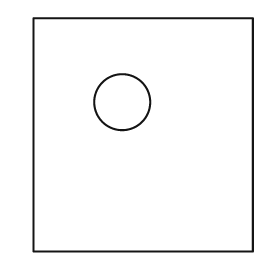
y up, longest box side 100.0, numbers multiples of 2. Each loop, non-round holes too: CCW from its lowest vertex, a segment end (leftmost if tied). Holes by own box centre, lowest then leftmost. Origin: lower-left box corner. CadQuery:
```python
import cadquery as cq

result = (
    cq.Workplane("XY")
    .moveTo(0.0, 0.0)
    .lineTo(94.0, 0.0)
    .lineTo(94.0, 100.0)
    .lineTo(0.0, 100.0)
    .close()
    .moveTo(38.0, 64.0)
    .circle(12.0)
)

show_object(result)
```